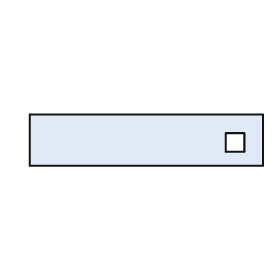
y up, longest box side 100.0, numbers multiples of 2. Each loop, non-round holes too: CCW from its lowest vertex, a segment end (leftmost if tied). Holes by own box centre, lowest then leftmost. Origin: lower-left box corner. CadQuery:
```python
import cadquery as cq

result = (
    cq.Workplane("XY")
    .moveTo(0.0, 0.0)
    .lineTo(100.0, 0.0)
    .lineTo(100.0, 22.0)
    .lineTo(0.0, 22.0)
    .close()
    .moveTo(84.0, 6.0)
    .lineTo(92.0, 6.0)
    .lineTo(92.0, 14.0)
    .lineTo(84.0, 14.0)
    .close()
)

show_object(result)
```